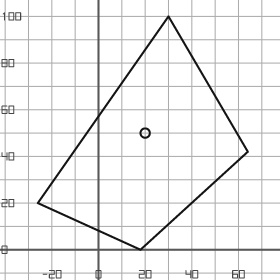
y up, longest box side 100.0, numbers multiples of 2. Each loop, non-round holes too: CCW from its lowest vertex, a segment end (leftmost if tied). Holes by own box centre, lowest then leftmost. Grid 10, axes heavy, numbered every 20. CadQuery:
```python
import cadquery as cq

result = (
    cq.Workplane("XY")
    .moveTo(18.0, 0.0)
    .lineTo(64.0, 42.0)
    .lineTo(30.0, 100.0)
    .lineTo(-26.0, 20.0)
    .close()
    .moveTo(20.0, 50.0)
    .circle(2.0)
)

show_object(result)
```